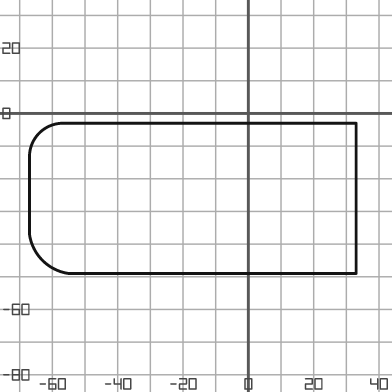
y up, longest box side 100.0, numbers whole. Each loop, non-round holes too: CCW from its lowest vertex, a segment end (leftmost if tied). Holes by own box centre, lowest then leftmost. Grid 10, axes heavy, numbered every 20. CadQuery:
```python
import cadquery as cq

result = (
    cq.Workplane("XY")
    .moveTo(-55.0, -49.0)
    .lineTo(33.0, -49.0)
    .lineTo(33.0, -3.0)
    .lineTo(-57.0, -3.0)
    .threePointArc((-64.0, -6.0), (-67.0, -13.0))
    .lineTo(-67.0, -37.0)
    .threePointArc((-63.0, -45.0), (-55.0, -49.0))
    .close()
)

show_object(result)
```